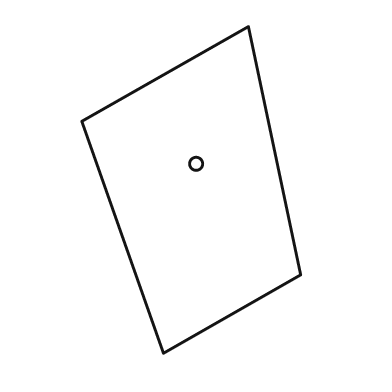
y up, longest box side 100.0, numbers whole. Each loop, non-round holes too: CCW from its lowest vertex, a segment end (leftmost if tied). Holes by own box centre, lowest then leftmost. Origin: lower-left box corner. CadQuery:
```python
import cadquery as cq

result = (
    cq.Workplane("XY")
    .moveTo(25.0, 0.0)
    .lineTo(67.0, 24.0)
    .lineTo(51.0, 100.0)
    .lineTo(0.0, 71.0)
    .close()
    .moveTo(35.0, 58.0)
    .circle(2.0)
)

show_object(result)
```